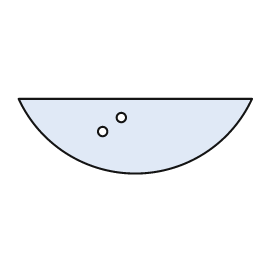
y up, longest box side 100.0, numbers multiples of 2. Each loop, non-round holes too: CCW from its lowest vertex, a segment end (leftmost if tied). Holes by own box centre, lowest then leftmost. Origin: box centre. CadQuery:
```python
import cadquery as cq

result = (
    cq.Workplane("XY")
    .moveTo(-50.0, 16.0)
    .threePointArc((0.0, -16.0), (50.0, 16.0))
    .close()
    .moveTo(-14.0, 2.0)
    .circle(2.0)
    .moveTo(-6.0, 8.0)
    .circle(2.0)
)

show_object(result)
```